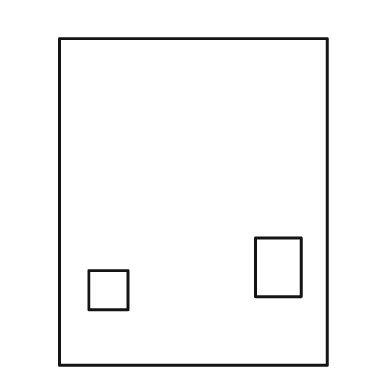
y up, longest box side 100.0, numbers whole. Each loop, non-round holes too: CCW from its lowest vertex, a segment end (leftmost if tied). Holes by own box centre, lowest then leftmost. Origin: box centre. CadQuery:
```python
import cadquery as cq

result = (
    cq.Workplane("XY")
    .moveTo(-41.0, -50.0)
    .lineTo(41.0, -50.0)
    .lineTo(41.0, 50.0)
    .lineTo(-41.0, 50.0)
    .close()
    .moveTo(-32.0, -33.0)
    .lineTo(-20.0, -33.0)
    .lineTo(-20.0, -21.0)
    .lineTo(-32.0, -21.0)
    .close()
    .moveTo(19.0, -29.0)
    .lineTo(33.0, -29.0)
    .lineTo(33.0, -11.0)
    .lineTo(19.0, -11.0)
    .close()
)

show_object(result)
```